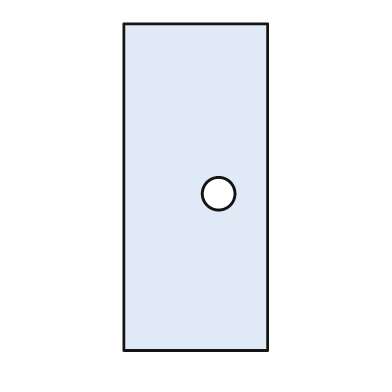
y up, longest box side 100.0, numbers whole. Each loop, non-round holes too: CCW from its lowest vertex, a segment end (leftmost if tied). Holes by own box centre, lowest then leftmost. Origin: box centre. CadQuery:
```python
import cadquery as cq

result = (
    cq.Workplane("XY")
    .moveTo(-22.0, -50.0)
    .lineTo(22.0, -50.0)
    .lineTo(22.0, 50.0)
    .lineTo(-22.0, 50.0)
    .close()
    .moveTo(7.0, -2.0)
    .circle(5.0)
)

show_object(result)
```